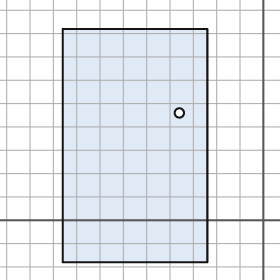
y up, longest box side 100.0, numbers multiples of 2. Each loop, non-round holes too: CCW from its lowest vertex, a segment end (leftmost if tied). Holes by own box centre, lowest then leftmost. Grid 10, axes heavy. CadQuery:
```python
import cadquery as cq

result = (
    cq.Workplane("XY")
    .moveTo(-86.0, -18.0)
    .lineTo(-24.0, -18.0)
    .lineTo(-24.0, 82.0)
    .lineTo(-86.0, 82.0)
    .close()
    .moveTo(-36.0, 46.0)
    .circle(2.0)
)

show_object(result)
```